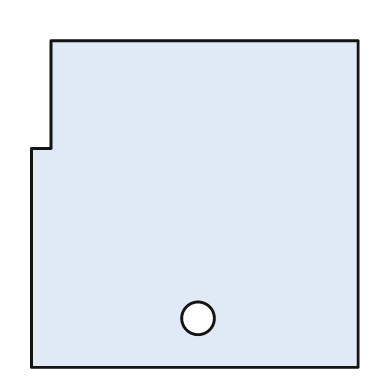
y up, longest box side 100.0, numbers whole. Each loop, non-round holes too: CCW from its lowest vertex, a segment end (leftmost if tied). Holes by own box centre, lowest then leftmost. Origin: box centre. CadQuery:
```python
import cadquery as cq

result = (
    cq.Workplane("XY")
    .moveTo(-50.0, -50.0)
    .lineTo(50.0, -50.0)
    .lineTo(50.0, 50.0)
    .lineTo(-44.0, 50.0)
    .lineTo(-44.0, 17.0)
    .lineTo(-50.0, 17.0)
    .close()
    .moveTo(1.0, -35.0)
    .circle(5.0)
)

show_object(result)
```